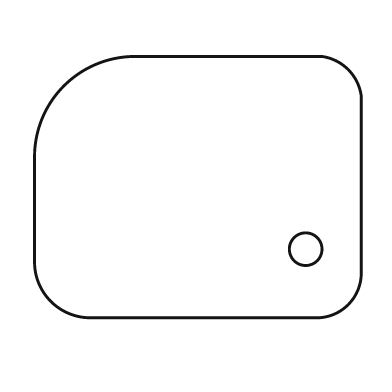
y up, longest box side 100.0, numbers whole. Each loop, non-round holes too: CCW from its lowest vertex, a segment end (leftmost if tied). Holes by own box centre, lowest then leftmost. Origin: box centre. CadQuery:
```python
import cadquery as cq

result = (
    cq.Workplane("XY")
    .moveTo(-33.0, -40.0)
    .lineTo(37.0, -40.0)
    .threePointArc((46.0, -36.0), (50.0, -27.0))
    .lineTo(50.0, 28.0)
    .threePointArc((46.0, 36.0), (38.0, 40.0))
    .lineTo(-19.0, 40.0)
    .threePointArc((-41.0, 31.0), (-50.0, 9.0))
    .lineTo(-50.0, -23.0)
    .threePointArc((-45.0, -35.0), (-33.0, -40.0))
    .close()
    .moveTo(33.0, -19.0)
    .circle(5.0)
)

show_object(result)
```